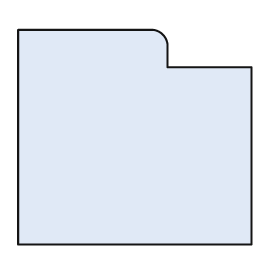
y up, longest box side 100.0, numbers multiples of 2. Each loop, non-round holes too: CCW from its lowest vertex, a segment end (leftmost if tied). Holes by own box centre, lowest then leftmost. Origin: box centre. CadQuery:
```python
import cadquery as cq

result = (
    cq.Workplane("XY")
    .moveTo(-50.0, -46.0)
    .lineTo(50.0, -46.0)
    .lineTo(50.0, 30.0)
    .lineTo(14.0, 30.0)
    .lineTo(14.0, 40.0)
    .threePointArc((12.0, 44.0), (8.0, 46.0))
    .lineTo(-50.0, 46.0)
    .close()
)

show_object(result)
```